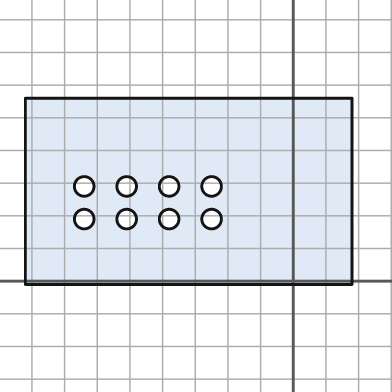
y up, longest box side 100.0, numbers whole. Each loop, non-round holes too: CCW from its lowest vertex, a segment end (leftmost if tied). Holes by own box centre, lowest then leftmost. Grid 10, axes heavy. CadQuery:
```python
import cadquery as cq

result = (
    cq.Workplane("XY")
    .moveTo(-82.0, -1.0)
    .lineTo(18.0, -1.0)
    .lineTo(18.0, 56.0)
    .lineTo(-82.0, 56.0)
    .close()
    .moveTo(-64.0, 19.0)
    .circle(3.0)
    .moveTo(-51.0, 19.0)
    .circle(3.0)
    .moveTo(-38.0, 19.0)
    .circle(3.0)
    .moveTo(-25.0, 19.0)
    .circle(3.0)
    .moveTo(-64.0, 29.0)
    .circle(3.0)
    .moveTo(-51.0, 29.0)
    .circle(3.0)
    .moveTo(-38.0, 29.0)
    .circle(3.0)
    .moveTo(-25.0, 29.0)
    .circle(3.0)
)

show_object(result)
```